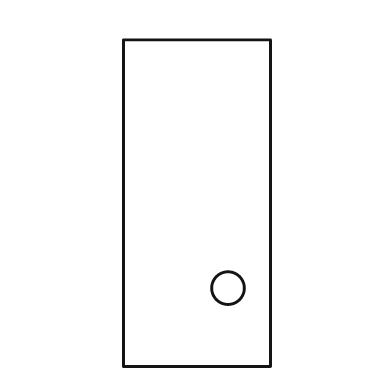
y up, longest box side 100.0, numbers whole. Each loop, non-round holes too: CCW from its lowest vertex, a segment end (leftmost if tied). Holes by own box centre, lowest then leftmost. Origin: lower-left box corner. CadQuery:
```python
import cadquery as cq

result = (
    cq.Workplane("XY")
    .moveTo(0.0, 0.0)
    .lineTo(45.0, 0.0)
    .lineTo(45.0, 100.0)
    .lineTo(0.0, 100.0)
    .close()
    .moveTo(32.0, 24.0)
    .circle(5.0)
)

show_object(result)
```